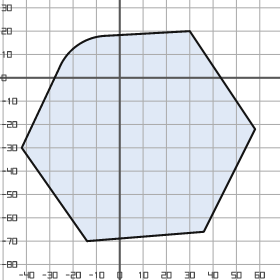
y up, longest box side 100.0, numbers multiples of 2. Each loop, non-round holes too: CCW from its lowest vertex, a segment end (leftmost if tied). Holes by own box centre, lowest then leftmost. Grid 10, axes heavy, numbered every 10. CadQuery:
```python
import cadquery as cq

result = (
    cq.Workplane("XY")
    .moveTo(-14.0, -70.0)
    .lineTo(36.0, -66.0)
    .lineTo(58.0, -22.0)
    .lineTo(30.0, 20.0)
    .lineTo(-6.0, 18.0)
    .threePointArc((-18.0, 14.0), (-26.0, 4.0))
    .lineTo(-42.0, -30.0)
    .close()
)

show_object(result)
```